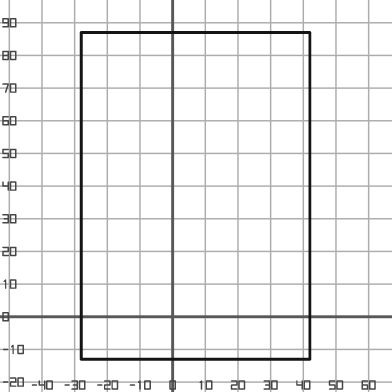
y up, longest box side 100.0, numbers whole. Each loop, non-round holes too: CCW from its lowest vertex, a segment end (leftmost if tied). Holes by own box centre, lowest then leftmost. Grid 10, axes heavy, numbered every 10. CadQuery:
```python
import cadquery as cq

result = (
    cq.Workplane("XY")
    .moveTo(-28.0, -13.0)
    .lineTo(42.0, -13.0)
    .lineTo(42.0, 87.0)
    .lineTo(-28.0, 87.0)
    .close()
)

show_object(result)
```